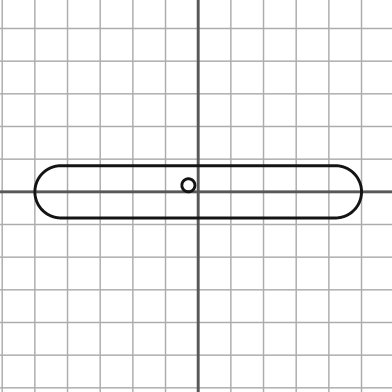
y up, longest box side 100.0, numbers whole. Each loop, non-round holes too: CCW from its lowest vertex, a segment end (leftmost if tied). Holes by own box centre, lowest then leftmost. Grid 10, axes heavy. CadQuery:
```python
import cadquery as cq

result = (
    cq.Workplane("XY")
    .moveTo(-42.0, -8.0)
    .lineTo(42.0, -8.0)
    .threePointArc((50.0, 0.0), (42.0, 8.0))
    .lineTo(-42.0, 8.0)
    .threePointArc((-50.0, 0.0), (-42.0, -8.0))
    .close()
    .moveTo(-3.0, 2.0)
    .circle(2.0)
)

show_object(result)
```